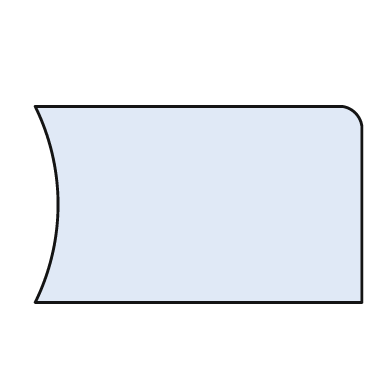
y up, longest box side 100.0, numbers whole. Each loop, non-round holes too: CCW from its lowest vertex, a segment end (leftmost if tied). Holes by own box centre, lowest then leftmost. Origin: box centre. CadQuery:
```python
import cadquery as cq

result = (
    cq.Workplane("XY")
    .moveTo(-50.0, -30.0)
    .lineTo(50.0, -30.0)
    .lineTo(50.0, 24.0)
    .threePointArc((48.0, 28.0), (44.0, 30.0))
    .lineTo(-50.0, 30.0)
    .threePointArc((-43.0, 0.0), (-50.0, -30.0))
    .close()
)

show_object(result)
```